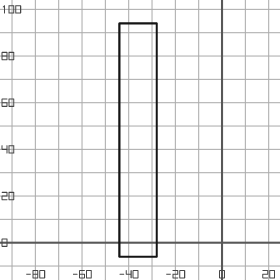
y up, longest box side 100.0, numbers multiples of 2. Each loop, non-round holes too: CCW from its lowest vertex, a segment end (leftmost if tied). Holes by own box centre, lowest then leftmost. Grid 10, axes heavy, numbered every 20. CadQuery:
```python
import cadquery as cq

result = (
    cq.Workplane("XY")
    .moveTo(-44.0, -6.0)
    .lineTo(-28.0, -6.0)
    .lineTo(-28.0, 94.0)
    .lineTo(-44.0, 94.0)
    .close()
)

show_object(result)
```